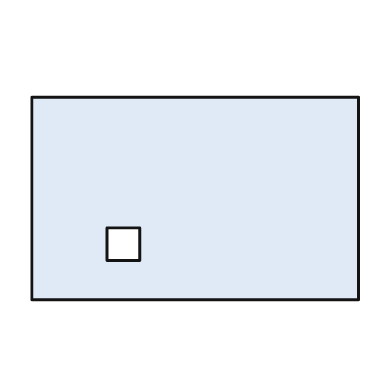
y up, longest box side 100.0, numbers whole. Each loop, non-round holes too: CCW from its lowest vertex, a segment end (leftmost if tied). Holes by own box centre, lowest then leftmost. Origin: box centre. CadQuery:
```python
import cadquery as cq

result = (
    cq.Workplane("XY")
    .moveTo(-50.0, -31.0)
    .lineTo(50.0, -31.0)
    .lineTo(50.0, 31.0)
    .lineTo(-50.0, 31.0)
    .close()
    .moveTo(-27.0, -19.0)
    .lineTo(-17.0, -19.0)
    .lineTo(-17.0, -9.0)
    .lineTo(-27.0, -9.0)
    .close()
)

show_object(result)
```